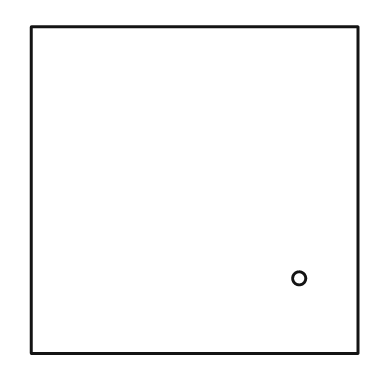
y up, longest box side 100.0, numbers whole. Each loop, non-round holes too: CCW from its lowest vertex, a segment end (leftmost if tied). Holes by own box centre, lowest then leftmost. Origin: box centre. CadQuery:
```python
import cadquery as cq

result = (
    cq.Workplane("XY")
    .moveTo(-50.0, -50.0)
    .lineTo(50.0, -50.0)
    .lineTo(50.0, 50.0)
    .lineTo(-50.0, 50.0)
    .close()
    .moveTo(32.0, -27.0)
    .circle(2.0)
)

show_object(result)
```